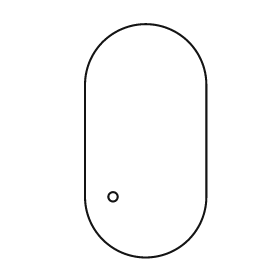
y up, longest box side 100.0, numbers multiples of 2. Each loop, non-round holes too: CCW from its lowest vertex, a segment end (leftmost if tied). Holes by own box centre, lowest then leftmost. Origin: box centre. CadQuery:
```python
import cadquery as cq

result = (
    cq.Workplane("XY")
    .moveTo(-26.0, -24.0)
    .threePointArc((0.0, -50.0), (26.0, -24.0))
    .lineTo(26.0, 24.0)
    .threePointArc((0.0, 50.0), (-26.0, 24.0))
    .close()
    .moveTo(-14.0, -24.0)
    .circle(2.0)
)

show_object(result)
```